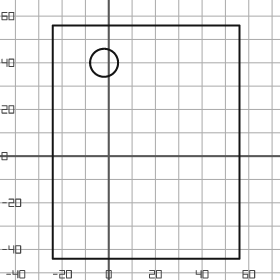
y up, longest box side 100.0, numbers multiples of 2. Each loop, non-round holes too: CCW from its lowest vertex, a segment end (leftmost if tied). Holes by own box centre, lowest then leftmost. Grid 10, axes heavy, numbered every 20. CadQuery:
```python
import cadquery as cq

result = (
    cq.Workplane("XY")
    .moveTo(-24.0, -44.0)
    .lineTo(56.0, -44.0)
    .lineTo(56.0, 56.0)
    .lineTo(-24.0, 56.0)
    .close()
    .moveTo(-2.0, 40.0)
    .circle(6.0)
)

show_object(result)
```